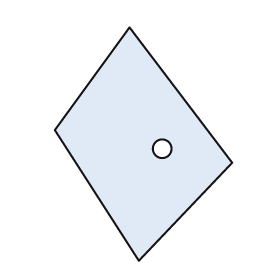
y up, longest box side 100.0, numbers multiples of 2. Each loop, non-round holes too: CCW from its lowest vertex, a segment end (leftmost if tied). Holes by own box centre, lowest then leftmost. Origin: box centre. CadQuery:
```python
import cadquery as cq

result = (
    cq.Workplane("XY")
    .moveTo(-2.0, -50.0)
    .lineTo(38.0, -8.0)
    .lineTo(-6.0, 50.0)
    .lineTo(-38.0, 6.0)
    .close()
    .moveTo(8.0, -2.0)
    .circle(4.0)
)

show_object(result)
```